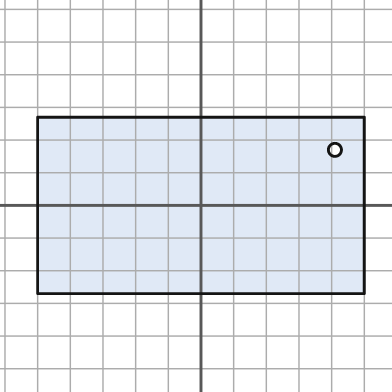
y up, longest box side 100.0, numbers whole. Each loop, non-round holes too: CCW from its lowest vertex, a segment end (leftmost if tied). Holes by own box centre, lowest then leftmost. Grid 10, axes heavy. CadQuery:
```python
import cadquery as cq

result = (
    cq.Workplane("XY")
    .moveTo(-50.0, -27.0)
    .lineTo(50.0, -27.0)
    .lineTo(50.0, 27.0)
    .lineTo(-50.0, 27.0)
    .close()
    .moveTo(41.0, 17.0)
    .circle(2.0)
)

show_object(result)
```